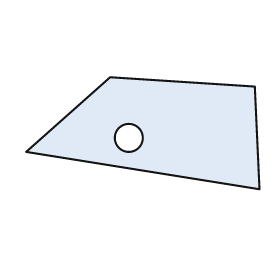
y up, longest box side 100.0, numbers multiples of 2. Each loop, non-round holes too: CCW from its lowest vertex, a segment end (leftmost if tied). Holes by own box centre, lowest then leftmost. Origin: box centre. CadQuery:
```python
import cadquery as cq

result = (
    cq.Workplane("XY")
    .moveTo(50.0, -24.0)
    .lineTo(48.0, 20.0)
    .lineTo(-14.0, 24.0)
    .lineTo(-50.0, -8.0)
    .close()
    .moveTo(-6.0, -2.0)
    .circle(6.0)
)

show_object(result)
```